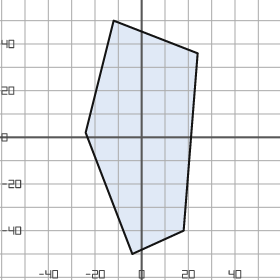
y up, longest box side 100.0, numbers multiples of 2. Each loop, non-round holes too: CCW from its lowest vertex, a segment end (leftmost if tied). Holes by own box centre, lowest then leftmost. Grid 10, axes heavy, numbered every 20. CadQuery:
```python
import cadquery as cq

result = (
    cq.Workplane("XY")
    .moveTo(-4.0, -50.0)
    .lineTo(18.0, -40.0)
    .lineTo(24.0, 36.0)
    .lineTo(-12.0, 50.0)
    .lineTo(-24.0, 2.0)
    .close()
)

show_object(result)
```